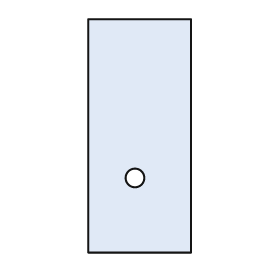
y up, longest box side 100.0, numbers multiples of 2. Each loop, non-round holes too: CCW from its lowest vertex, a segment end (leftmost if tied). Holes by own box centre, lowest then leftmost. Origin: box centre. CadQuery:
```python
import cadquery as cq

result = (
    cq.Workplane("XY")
    .moveTo(-22.0, -50.0)
    .lineTo(22.0, -50.0)
    .lineTo(22.0, 50.0)
    .lineTo(-22.0, 50.0)
    .close()
    .moveTo(-2.0, -18.0)
    .circle(4.0)
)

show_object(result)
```